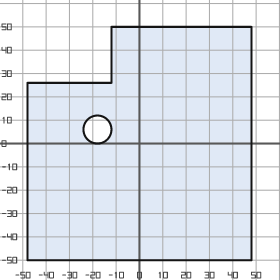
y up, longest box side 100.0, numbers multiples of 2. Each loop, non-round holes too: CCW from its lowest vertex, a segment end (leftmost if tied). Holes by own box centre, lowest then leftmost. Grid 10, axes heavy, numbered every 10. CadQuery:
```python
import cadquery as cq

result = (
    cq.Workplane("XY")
    .moveTo(-48.0, -50.0)
    .lineTo(48.0, -50.0)
    .lineTo(48.0, 50.0)
    .lineTo(-12.0, 50.0)
    .lineTo(-12.0, 26.0)
    .lineTo(-48.0, 26.0)
    .close()
    .moveTo(-18.0, 6.0)
    .circle(6.0)
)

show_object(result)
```